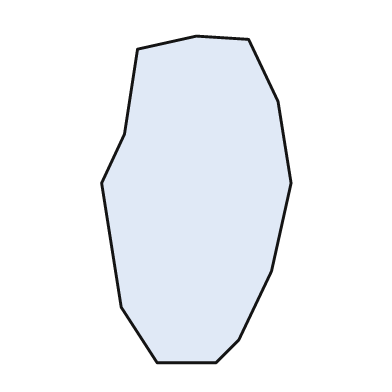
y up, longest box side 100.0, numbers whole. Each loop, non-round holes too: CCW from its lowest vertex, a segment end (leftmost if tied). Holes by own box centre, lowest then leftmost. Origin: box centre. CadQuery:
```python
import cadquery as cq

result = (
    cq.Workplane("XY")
    .moveTo(-12.0, -50.0)
    .lineTo(6.0, -50.0)
    .lineTo(13.0, -43.0)
    .lineTo(23.0, -22.0)
    .lineTo(29.0, 5.0)
    .lineTo(25.0, 30.0)
    .lineTo(16.0, 49.0)
    .lineTo(0.0, 50.0)
    .lineTo(-18.0, 46.0)
    .lineTo(-22.0, 20.0)
    .lineTo(-29.0, 5.0)
    .lineTo(-23.0, -33.0)
    .close()
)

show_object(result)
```